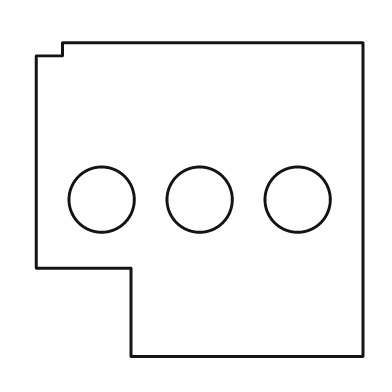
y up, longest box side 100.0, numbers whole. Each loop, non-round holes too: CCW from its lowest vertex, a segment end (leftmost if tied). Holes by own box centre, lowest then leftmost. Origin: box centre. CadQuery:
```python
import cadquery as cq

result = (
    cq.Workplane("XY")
    .moveTo(-21.0, -48.0)
    .lineTo(50.0, -48.0)
    .lineTo(50.0, 48.0)
    .lineTo(-42.0, 48.0)
    .lineTo(-42.0, 44.0)
    .lineTo(-50.0, 44.0)
    .lineTo(-50.0, -21.0)
    .lineTo(-21.0, -21.0)
    .close()
    .moveTo(-30.0, 0.0)
    .circle(10.0)
    .moveTo(0.0, 0.0)
    .circle(10.0)
    .moveTo(30.0, 0.0)
    .circle(10.0)
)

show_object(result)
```